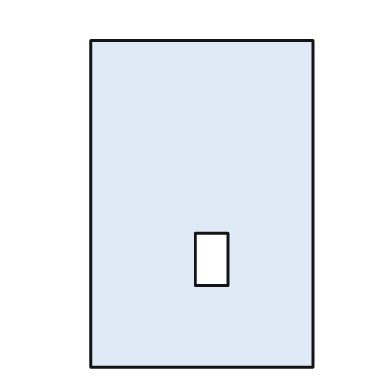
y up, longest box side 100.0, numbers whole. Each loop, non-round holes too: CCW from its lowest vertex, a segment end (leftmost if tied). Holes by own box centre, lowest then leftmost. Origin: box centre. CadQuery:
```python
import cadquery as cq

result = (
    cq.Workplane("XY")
    .moveTo(-34.0, -50.0)
    .lineTo(34.0, -50.0)
    .lineTo(34.0, 50.0)
    .lineTo(-34.0, 50.0)
    .close()
    .moveTo(-2.0, -25.0)
    .lineTo(8.0, -25.0)
    .lineTo(8.0, -9.0)
    .lineTo(-2.0, -9.0)
    .close()
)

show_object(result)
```